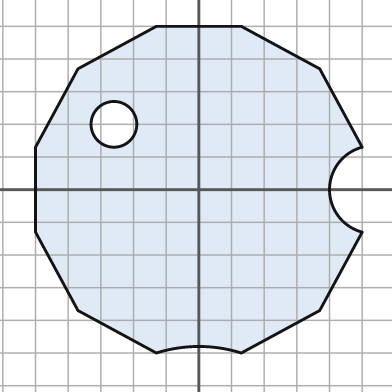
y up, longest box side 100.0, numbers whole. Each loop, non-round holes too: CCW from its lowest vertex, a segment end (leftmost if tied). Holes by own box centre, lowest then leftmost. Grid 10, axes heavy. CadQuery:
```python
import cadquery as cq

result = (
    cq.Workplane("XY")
    .moveTo(-13.0, -50.0)
    .threePointArc((0.0, -48.0), (13.0, -50.0))
    .lineTo(37.0, -37.0)
    .lineTo(50.0, -13.0)
    .threePointArc((40.0, 0.0), (50.0, 13.0))
    .lineTo(37.0, 37.0)
    .lineTo(13.0, 50.0)
    .lineTo(-13.0, 50.0)
    .lineTo(-37.0, 37.0)
    .lineTo(-50.0, 13.0)
    .lineTo(-50.0, -13.0)
    .lineTo(-37.0, -37.0)
    .close()
    .moveTo(-26.0, 20.0)
    .circle(7.0)
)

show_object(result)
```